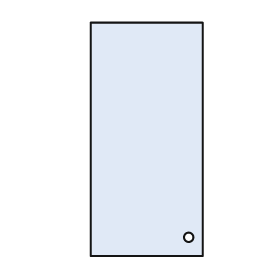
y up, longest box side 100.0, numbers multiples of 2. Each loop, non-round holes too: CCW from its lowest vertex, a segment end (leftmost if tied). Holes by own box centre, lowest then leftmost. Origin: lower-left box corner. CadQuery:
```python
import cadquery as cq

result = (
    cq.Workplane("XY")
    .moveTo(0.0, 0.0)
    .lineTo(48.0, 0.0)
    .lineTo(48.0, 100.0)
    .lineTo(0.0, 100.0)
    .close()
    .moveTo(42.0, 8.0)
    .circle(2.0)
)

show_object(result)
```